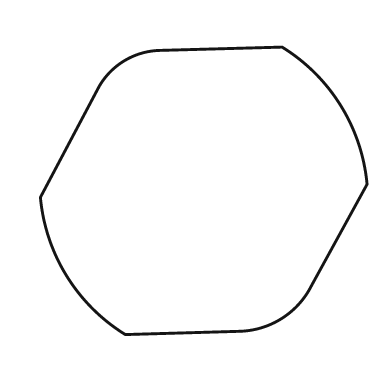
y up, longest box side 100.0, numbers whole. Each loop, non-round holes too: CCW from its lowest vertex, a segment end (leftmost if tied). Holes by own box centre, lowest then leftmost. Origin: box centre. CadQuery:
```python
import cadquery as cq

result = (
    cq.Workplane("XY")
    .moveTo(-24.0, -44.0)
    .lineTo(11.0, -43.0)
    .threePointArc((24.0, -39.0), (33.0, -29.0))
    .lineTo(50.0, 2.0)
    .threePointArc((42.0, 26.0), (24.0, 44.0))
    .lineTo(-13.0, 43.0)
    .threePointArc((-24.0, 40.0), (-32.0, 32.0))
    .lineTo(-50.0, -2.0)
    .threePointArc((-42.0, -26.0), (-24.0, -44.0))
    .close()
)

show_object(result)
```